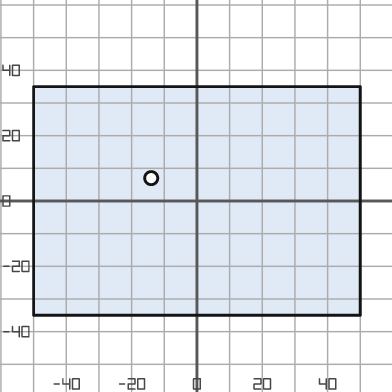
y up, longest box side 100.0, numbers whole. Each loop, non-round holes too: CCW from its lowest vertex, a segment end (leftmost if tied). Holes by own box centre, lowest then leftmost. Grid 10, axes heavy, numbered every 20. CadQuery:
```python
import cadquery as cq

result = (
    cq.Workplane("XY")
    .moveTo(-50.0, -35.0)
    .lineTo(50.0, -35.0)
    .lineTo(50.0, 35.0)
    .lineTo(-50.0, 35.0)
    .close()
    .moveTo(-14.0, 7.0)
    .circle(2.0)
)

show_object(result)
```